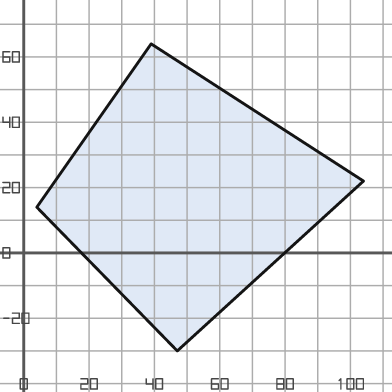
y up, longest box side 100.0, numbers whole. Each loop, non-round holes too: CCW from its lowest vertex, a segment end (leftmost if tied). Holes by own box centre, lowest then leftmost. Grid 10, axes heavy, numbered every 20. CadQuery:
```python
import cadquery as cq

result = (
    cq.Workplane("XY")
    .moveTo(47.0, -30.0)
    .lineTo(104.0, 22.0)
    .lineTo(39.0, 64.0)
    .lineTo(4.0, 14.0)
    .close()
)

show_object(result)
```